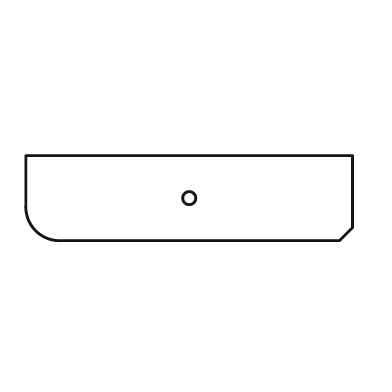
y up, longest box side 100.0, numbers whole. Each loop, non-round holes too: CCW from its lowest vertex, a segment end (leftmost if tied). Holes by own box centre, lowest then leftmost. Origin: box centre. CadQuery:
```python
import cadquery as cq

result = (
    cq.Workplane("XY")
    .moveTo(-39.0, -13.0)
    .lineTo(46.0, -13.0)
    .lineTo(50.0, -9.0)
    .lineTo(50.0, 13.0)
    .lineTo(-50.0, 13.0)
    .lineTo(-50.0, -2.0)
    .threePointArc((-47.0, -10.0), (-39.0, -13.0))
    .close()
    .moveTo(0.0, 0.0)
    .circle(2.0)
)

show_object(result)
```